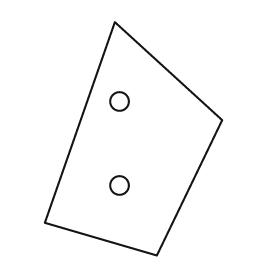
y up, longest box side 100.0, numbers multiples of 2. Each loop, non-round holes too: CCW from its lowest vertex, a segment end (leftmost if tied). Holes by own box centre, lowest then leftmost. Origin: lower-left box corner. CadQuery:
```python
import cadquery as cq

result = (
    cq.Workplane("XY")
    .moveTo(48.0, 0.0)
    .lineTo(76.0, 58.0)
    .lineTo(30.0, 100.0)
    .lineTo(0.0, 14.0)
    .close()
    .moveTo(32.0, 30.0)
    .circle(4.0)
    .moveTo(32.0, 66.0)
    .circle(4.0)
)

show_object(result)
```